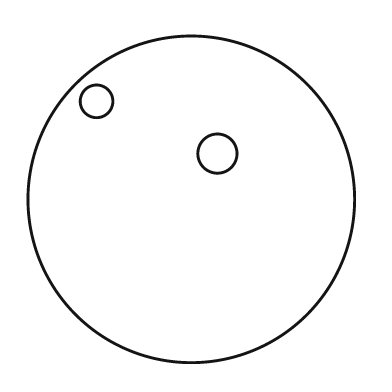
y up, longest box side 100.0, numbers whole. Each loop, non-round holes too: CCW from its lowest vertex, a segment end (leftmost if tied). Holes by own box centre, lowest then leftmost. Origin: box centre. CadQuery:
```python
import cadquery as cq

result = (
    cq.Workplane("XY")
    .moveTo(0.0, 0.0)
    .circle(50.0)
    .moveTo(8.0, 14.0)
    .circle(6.0)
    .moveTo(-29.0, 30.0)
    .circle(5.0)
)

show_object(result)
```